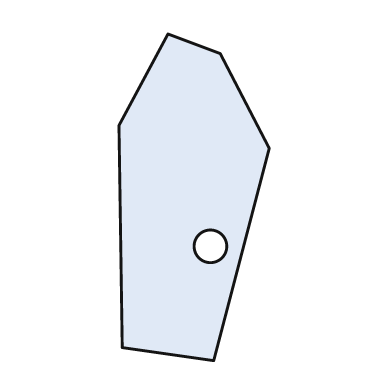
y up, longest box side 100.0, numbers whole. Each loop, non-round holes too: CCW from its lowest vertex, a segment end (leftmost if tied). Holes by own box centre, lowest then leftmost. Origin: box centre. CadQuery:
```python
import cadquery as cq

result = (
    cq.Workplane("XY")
    .moveTo(6.0, -50.0)
    .lineTo(23.0, 15.0)
    .lineTo(8.0, 44.0)
    .lineTo(-8.0, 50.0)
    .lineTo(-23.0, 22.0)
    .lineTo(-22.0, -46.0)
    .close()
    .moveTo(5.0, -15.0)
    .circle(5.0)
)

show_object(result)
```